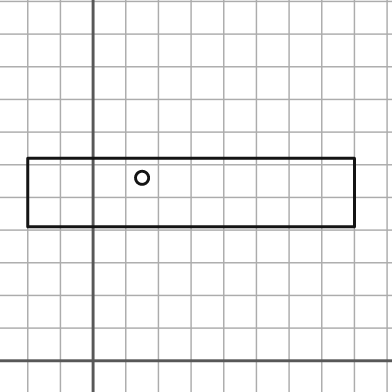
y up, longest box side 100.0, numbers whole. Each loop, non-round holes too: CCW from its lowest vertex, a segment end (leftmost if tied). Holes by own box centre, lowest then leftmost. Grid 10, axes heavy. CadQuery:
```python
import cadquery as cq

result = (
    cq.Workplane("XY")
    .moveTo(-20.0, 41.0)
    .lineTo(80.0, 41.0)
    .lineTo(80.0, 62.0)
    .lineTo(-20.0, 62.0)
    .close()
    .moveTo(15.0, 56.0)
    .circle(2.0)
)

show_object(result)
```